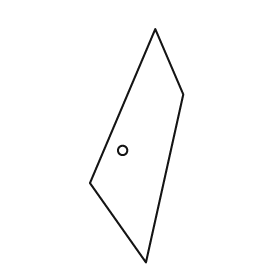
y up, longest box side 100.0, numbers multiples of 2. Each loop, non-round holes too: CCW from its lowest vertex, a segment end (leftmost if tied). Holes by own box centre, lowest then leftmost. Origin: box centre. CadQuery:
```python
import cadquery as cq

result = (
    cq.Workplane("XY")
    .moveTo(4.0, -50.0)
    .lineTo(20.0, 22.0)
    .lineTo(8.0, 50.0)
    .lineTo(-20.0, -16.0)
    .close()
    .moveTo(-6.0, -2.0)
    .circle(2.0)
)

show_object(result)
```